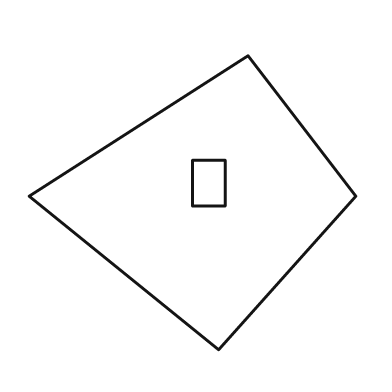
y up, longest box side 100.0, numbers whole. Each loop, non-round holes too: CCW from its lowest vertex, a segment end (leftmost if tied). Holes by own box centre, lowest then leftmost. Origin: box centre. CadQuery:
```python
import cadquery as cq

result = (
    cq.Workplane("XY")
    .moveTo(8.0, -45.0)
    .lineTo(50.0, 2.0)
    .lineTo(17.0, 45.0)
    .lineTo(-50.0, 2.0)
    .close()
    .moveTo(0.0, -1.0)
    .lineTo(10.0, -1.0)
    .lineTo(10.0, 13.0)
    .lineTo(0.0, 13.0)
    .close()
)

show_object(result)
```